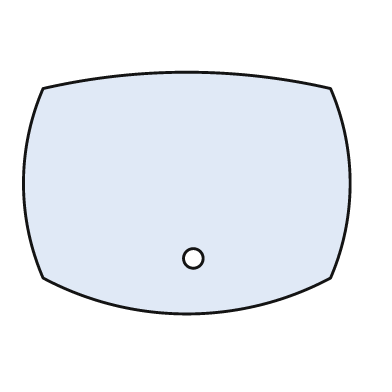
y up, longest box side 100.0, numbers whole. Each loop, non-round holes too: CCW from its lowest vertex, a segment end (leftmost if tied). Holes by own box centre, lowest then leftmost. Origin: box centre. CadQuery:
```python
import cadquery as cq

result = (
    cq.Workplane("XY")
    .moveTo(-44.0, -26.0)
    .threePointArc((0.0, -37.0), (44.0, -26.0))
    .threePointArc((50.0, 3.0), (44.0, 32.0))
    .threePointArc((0.0, 37.0), (-44.0, 32.0))
    .threePointArc((-50.0, 3.0), (-44.0, -26.0))
    .close()
    .moveTo(2.0, -20.0)
    .circle(3.0)
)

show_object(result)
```